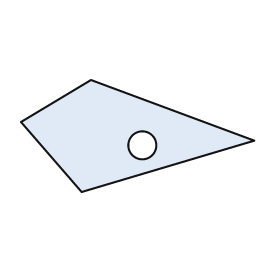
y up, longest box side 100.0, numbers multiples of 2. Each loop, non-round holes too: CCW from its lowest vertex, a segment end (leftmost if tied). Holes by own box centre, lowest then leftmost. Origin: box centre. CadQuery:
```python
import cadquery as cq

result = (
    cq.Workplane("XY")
    .moveTo(-24.0, -24.0)
    .lineTo(50.0, -2.0)
    .lineTo(-20.0, 24.0)
    .lineTo(-50.0, 6.0)
    .close()
    .moveTo(2.0, -4.0)
    .circle(6.0)
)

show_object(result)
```